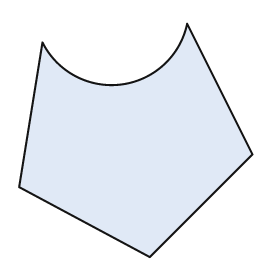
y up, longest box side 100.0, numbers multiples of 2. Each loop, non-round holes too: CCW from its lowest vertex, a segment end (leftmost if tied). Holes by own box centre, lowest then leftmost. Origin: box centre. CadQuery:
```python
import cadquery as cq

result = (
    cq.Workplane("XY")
    .moveTo(6.0, -50.0)
    .lineTo(50.0, -6.0)
    .lineTo(22.0, 50.0)
    .threePointArc((-6.0, 24.0), (-40.0, 42.0))
    .lineTo(-50.0, -20.0)
    .close()
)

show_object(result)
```